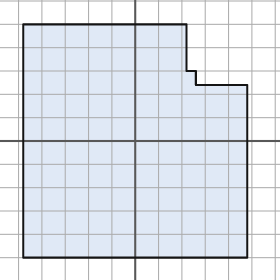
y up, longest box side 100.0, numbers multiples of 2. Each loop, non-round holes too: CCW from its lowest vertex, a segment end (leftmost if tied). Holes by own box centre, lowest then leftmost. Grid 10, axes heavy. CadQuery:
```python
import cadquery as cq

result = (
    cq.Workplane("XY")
    .moveTo(-48.0, -50.0)
    .lineTo(48.0, -50.0)
    .lineTo(48.0, 24.0)
    .lineTo(26.0, 24.0)
    .lineTo(26.0, 30.0)
    .lineTo(22.0, 30.0)
    .lineTo(22.0, 50.0)
    .lineTo(-48.0, 50.0)
    .close()
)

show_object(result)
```